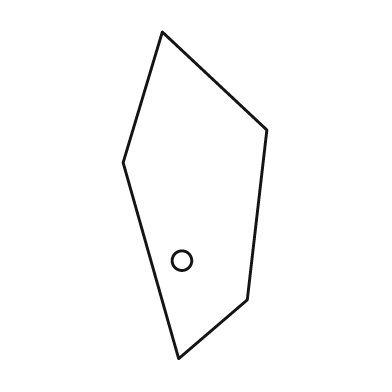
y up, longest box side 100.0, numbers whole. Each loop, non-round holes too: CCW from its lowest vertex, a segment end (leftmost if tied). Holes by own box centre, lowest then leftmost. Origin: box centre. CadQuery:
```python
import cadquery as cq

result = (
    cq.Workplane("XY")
    .moveTo(-5.0, -50.0)
    .lineTo(16.0, -32.0)
    .lineTo(22.0, 20.0)
    .lineTo(-10.0, 50.0)
    .lineTo(-22.0, 10.0)
    .close()
    .moveTo(-4.0, -20.0)
    .circle(3.0)
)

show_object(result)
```